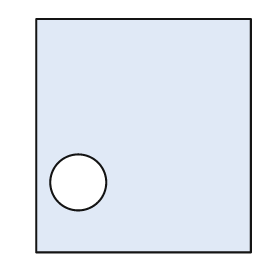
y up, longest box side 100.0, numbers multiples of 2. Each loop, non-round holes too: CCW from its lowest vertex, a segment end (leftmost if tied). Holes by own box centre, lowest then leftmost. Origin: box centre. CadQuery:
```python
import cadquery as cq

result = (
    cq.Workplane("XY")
    .moveTo(-46.0, -50.0)
    .lineTo(46.0, -50.0)
    .lineTo(46.0, 50.0)
    .lineTo(-46.0, 50.0)
    .close()
    .moveTo(-28.0, -20.0)
    .circle(12.0)
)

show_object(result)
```